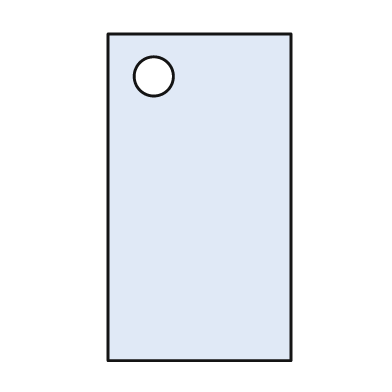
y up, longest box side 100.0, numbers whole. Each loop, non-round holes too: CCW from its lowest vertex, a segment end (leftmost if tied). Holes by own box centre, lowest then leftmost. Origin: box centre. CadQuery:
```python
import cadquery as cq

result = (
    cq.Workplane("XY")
    .moveTo(-28.0, -50.0)
    .lineTo(28.0, -50.0)
    .lineTo(28.0, 50.0)
    .lineTo(-28.0, 50.0)
    .close()
    .moveTo(-14.0, 37.0)
    .circle(6.0)
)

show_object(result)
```